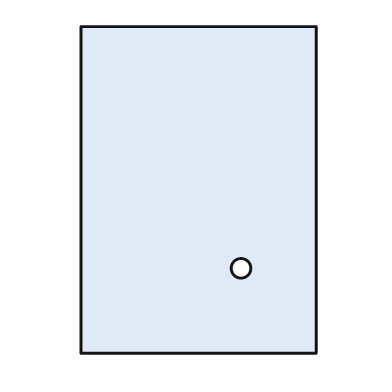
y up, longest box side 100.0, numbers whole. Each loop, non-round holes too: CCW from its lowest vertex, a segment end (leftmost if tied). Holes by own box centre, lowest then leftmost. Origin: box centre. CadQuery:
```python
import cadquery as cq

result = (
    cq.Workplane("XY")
    .moveTo(-36.0, -50.0)
    .lineTo(36.0, -50.0)
    .lineTo(36.0, 50.0)
    .lineTo(-36.0, 50.0)
    .close()
    .moveTo(13.0, -24.0)
    .circle(3.0)
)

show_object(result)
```